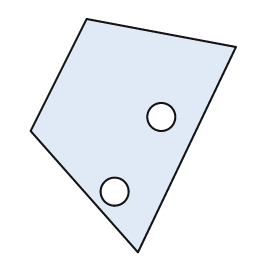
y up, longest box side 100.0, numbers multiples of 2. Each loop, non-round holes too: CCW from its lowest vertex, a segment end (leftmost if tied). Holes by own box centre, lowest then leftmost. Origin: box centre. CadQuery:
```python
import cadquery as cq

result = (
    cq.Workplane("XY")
    .moveTo(2.0, -50.0)
    .lineTo(44.0, 38.0)
    .lineTo(-20.0, 50.0)
    .lineTo(-44.0, 2.0)
    .close()
    .moveTo(-8.0, -24.0)
    .circle(6.0)
    .moveTo(12.0, 8.0)
    .circle(6.0)
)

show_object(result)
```